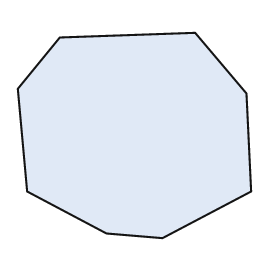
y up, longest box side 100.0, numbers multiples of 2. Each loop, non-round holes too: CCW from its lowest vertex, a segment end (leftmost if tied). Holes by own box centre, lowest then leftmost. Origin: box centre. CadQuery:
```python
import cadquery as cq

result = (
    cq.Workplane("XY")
    .moveTo(12.0, -44.0)
    .lineTo(50.0, -24.0)
    .lineTo(48.0, 18.0)
    .lineTo(26.0, 44.0)
    .lineTo(-32.0, 42.0)
    .lineTo(-50.0, 20.0)
    .lineTo(-46.0, -24.0)
    .lineTo(-12.0, -42.0)
    .close()
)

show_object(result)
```